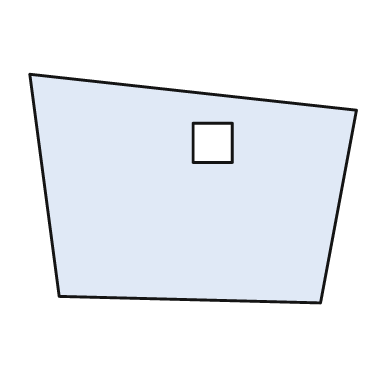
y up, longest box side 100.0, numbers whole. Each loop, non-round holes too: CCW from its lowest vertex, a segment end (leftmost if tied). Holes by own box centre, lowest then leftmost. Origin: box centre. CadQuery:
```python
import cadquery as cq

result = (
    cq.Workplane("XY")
    .moveTo(39.0, -35.0)
    .lineTo(50.0, 24.0)
    .lineTo(-50.0, 35.0)
    .lineTo(-41.0, -33.0)
    .close()
    .moveTo(0.0, 8.0)
    .lineTo(12.0, 8.0)
    .lineTo(12.0, 20.0)
    .lineTo(0.0, 20.0)
    .close()
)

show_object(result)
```